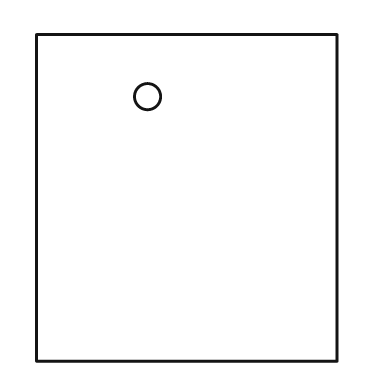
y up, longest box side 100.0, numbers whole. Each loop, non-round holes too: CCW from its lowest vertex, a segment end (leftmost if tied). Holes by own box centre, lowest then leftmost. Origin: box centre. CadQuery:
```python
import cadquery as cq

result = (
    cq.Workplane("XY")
    .moveTo(-46.0, -50.0)
    .lineTo(46.0, -50.0)
    .lineTo(46.0, 50.0)
    .lineTo(-46.0, 50.0)
    .close()
    .moveTo(-12.0, 31.0)
    .circle(4.0)
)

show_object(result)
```